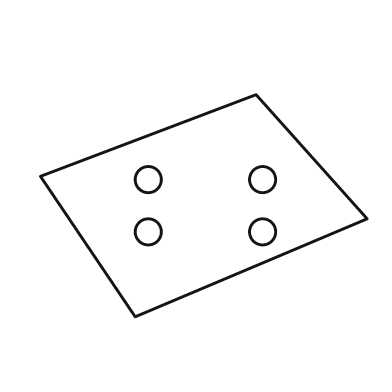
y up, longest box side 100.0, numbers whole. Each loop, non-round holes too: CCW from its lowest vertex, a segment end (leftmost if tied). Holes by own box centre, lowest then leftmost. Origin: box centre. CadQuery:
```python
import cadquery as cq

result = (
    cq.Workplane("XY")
    .moveTo(-21.0, -34.0)
    .lineTo(50.0, -4.0)
    .lineTo(16.0, 34.0)
    .lineTo(-50.0, 9.0)
    .close()
    .moveTo(-17.0, -8.0)
    .circle(4.0)
    .moveTo(18.0, -8.0)
    .circle(4.0)
    .moveTo(-17.0, 8.0)
    .circle(4.0)
    .moveTo(18.0, 8.0)
    .circle(4.0)
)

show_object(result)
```